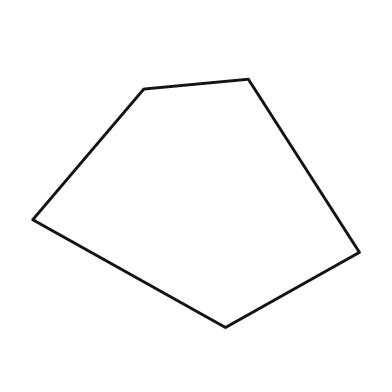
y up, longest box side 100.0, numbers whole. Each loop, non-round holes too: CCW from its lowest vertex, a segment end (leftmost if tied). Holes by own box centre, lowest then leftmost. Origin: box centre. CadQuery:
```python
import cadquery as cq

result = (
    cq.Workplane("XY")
    .moveTo(9.0, -38.0)
    .lineTo(50.0, -15.0)
    .lineTo(16.0, 38.0)
    .lineTo(-16.0, 35.0)
    .lineTo(-50.0, -5.0)
    .close()
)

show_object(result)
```